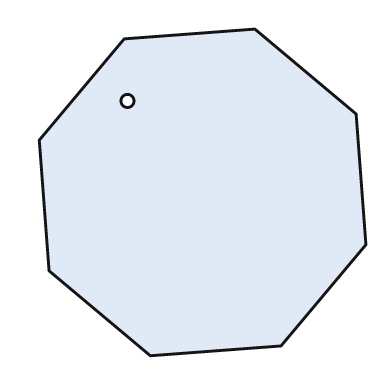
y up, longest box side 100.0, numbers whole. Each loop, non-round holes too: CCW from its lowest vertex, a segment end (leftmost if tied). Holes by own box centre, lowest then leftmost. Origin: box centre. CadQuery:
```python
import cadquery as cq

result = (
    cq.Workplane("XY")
    .moveTo(-16.0, -50.0)
    .lineTo(24.0, -47.0)
    .lineTo(50.0, -16.0)
    .lineTo(47.0, 24.0)
    .lineTo(16.0, 50.0)
    .lineTo(-24.0, 47.0)
    .lineTo(-50.0, 16.0)
    .lineTo(-47.0, -24.0)
    .close()
    .moveTo(-23.0, 28.0)
    .circle(2.0)
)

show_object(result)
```